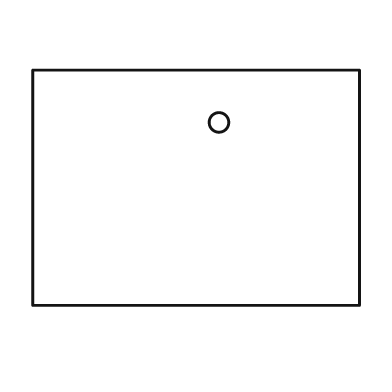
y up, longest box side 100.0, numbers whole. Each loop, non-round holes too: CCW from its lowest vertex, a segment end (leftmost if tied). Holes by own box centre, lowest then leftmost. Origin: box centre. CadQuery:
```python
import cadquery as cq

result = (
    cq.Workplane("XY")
    .moveTo(-50.0, -36.0)
    .lineTo(50.0, -36.0)
    .lineTo(50.0, 36.0)
    .lineTo(-50.0, 36.0)
    .close()
    .moveTo(7.0, 20.0)
    .circle(3.0)
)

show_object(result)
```